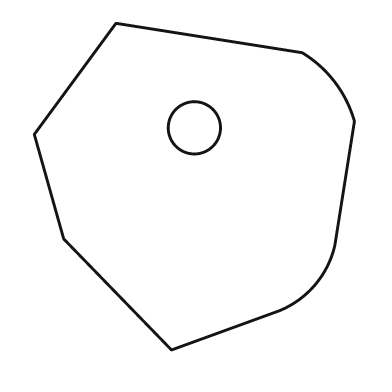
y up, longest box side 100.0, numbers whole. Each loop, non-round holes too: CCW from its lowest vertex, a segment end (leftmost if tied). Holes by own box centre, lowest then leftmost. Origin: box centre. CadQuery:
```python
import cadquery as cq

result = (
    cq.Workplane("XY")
    .moveTo(-7.0, -50.0)
    .lineTo(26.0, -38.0)
    .threePointArc((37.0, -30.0), (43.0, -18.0))
    .lineTo(49.0, 20.0)
    .threePointArc((43.0, 32.0), (33.0, 41.0))
    .lineTo(-24.0, 50.0)
    .lineTo(-49.0, 16.0)
    .lineTo(-40.0, -16.0)
    .close()
    .moveTo(0.0, 18.0)
    .circle(8.0)
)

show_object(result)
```